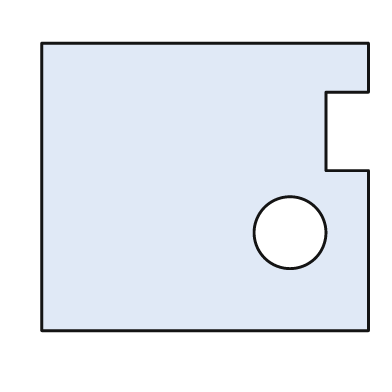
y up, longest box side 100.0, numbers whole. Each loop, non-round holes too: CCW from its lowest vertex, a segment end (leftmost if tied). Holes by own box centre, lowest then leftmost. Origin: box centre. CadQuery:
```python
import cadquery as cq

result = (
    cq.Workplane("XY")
    .moveTo(-50.0, -44.0)
    .lineTo(50.0, -44.0)
    .lineTo(50.0, 5.0)
    .lineTo(37.0, 5.0)
    .lineTo(37.0, 29.0)
    .lineTo(50.0, 29.0)
    .lineTo(50.0, 44.0)
    .lineTo(-50.0, 44.0)
    .close()
    .moveTo(26.0, -14.0)
    .circle(11.0)
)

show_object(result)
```